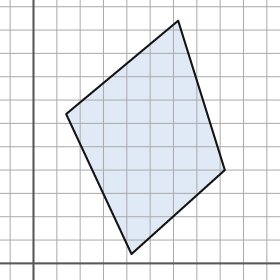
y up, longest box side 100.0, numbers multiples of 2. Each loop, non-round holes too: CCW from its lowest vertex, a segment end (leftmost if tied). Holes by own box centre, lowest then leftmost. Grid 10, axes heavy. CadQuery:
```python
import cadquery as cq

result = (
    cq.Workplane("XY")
    .moveTo(42.0, 4.0)
    .lineTo(82.0, 40.0)
    .lineTo(62.0, 104.0)
    .lineTo(14.0, 64.0)
    .close()
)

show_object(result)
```